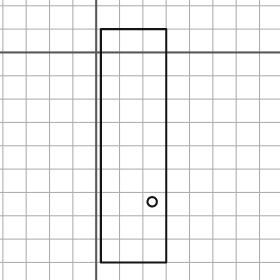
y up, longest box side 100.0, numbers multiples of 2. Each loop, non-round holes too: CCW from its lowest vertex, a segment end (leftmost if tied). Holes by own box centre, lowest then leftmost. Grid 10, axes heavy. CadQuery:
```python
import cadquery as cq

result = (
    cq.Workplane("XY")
    .moveTo(2.0, -90.0)
    .lineTo(30.0, -90.0)
    .lineTo(30.0, 10.0)
    .lineTo(2.0, 10.0)
    .close()
    .moveTo(24.0, -64.0)
    .circle(2.0)
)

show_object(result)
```